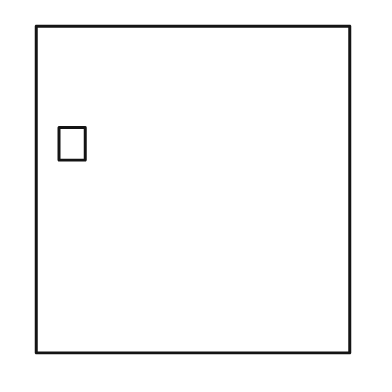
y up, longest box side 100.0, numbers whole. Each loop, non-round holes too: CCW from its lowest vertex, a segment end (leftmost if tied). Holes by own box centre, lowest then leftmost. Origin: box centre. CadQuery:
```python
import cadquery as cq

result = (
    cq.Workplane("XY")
    .moveTo(-48.0, -50.0)
    .lineTo(48.0, -50.0)
    .lineTo(48.0, 50.0)
    .lineTo(-48.0, 50.0)
    .close()
    .moveTo(-41.0, 9.0)
    .lineTo(-33.0, 9.0)
    .lineTo(-33.0, 19.0)
    .lineTo(-41.0, 19.0)
    .close()
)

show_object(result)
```